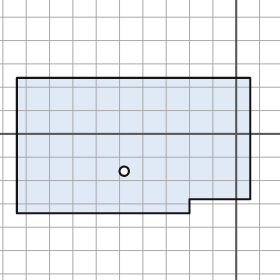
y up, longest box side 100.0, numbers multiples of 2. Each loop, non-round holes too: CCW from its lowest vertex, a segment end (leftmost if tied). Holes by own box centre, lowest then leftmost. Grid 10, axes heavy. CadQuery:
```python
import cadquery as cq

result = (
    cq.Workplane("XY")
    .moveTo(-94.0, -34.0)
    .lineTo(-20.0, -34.0)
    .lineTo(-20.0, -28.0)
    .lineTo(6.0, -28.0)
    .lineTo(6.0, 24.0)
    .lineTo(-94.0, 24.0)
    .close()
    .moveTo(-48.0, -16.0)
    .circle(2.0)
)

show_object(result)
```